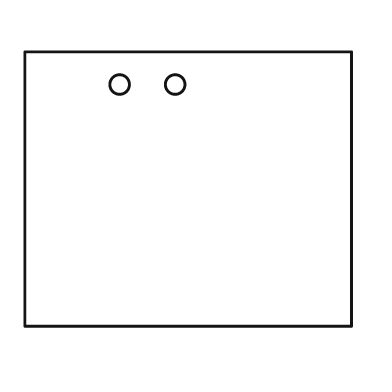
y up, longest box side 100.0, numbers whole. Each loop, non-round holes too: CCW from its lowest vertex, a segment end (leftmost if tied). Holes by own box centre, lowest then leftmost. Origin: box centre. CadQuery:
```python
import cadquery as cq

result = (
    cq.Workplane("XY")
    .moveTo(-50.0, -42.0)
    .lineTo(50.0, -42.0)
    .lineTo(50.0, 42.0)
    .lineTo(-50.0, 42.0)
    .close()
    .moveTo(-21.0, 32.0)
    .circle(3.0)
    .moveTo(-4.0, 32.0)
    .circle(3.0)
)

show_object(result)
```